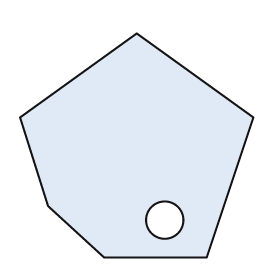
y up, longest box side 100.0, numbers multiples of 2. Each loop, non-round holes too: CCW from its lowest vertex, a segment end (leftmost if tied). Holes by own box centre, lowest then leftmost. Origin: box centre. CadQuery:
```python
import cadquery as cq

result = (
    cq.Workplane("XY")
    .moveTo(-14.0, -48.0)
    .lineTo(30.0, -48.0)
    .lineTo(50.0, 12.0)
    .lineTo(0.0, 48.0)
    .lineTo(-50.0, 12.0)
    .lineTo(-38.0, -26.0)
    .close()
    .moveTo(12.0, -32.0)
    .circle(8.0)
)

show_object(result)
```